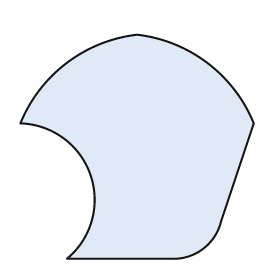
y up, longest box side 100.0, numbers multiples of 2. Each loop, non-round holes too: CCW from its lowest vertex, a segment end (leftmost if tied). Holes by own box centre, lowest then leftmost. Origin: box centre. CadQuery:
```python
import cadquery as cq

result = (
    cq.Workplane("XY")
    .moveTo(-30.0, -48.0)
    .lineTo(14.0, -48.0)
    .threePointArc((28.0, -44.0), (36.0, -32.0))
    .lineTo(50.0, 10.0)
    .threePointArc((30.0, 36.0), (0.0, 48.0))
    .threePointArc((-30.0, 36.0), (-50.0, 10.0))
    .threePointArc((-20.0, -12.0), (-30.0, -48.0))
    .close()
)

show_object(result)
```